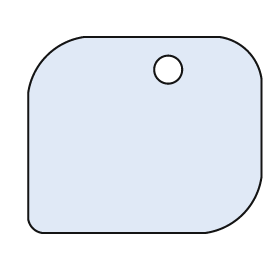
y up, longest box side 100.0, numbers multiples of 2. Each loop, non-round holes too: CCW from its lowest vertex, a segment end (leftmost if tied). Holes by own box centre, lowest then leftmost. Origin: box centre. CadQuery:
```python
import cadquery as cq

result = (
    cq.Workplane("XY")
    .moveTo(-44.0, -42.0)
    .lineTo(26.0, -42.0)
    .threePointArc((42.0, -34.0), (50.0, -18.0))
    .lineTo(50.0, 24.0)
    .threePointArc((44.0, 36.0), (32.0, 42.0))
    .lineTo(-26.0, 42.0)
    .threePointArc((-42.0, 34.0), (-50.0, 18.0))
    .lineTo(-50.0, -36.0)
    .threePointArc((-48.0, -40.0), (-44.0, -42.0))
    .close()
    .moveTo(10.0, 28.0)
    .circle(6.0)
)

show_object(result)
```